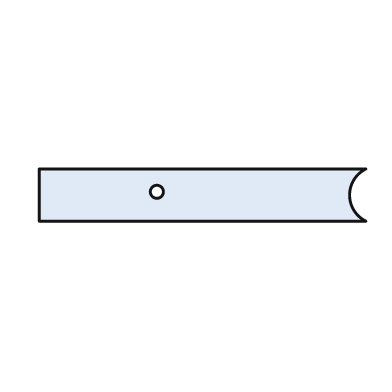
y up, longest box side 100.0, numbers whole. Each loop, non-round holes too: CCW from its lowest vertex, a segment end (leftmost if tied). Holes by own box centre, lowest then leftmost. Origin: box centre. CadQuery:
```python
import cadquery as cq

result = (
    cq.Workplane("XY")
    .moveTo(-50.0, -8.0)
    .lineTo(50.0, -8.0)
    .threePointArc((45.0, 0.0), (50.0, 8.0))
    .lineTo(-50.0, 8.0)
    .close()
    .moveTo(-14.0, 1.0)
    .circle(2.0)
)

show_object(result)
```